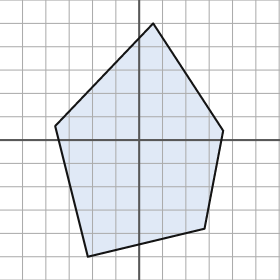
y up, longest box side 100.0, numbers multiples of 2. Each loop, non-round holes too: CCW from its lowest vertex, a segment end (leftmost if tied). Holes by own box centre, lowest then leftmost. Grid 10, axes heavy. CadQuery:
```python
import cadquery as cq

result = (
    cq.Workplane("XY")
    .moveTo(-22.0, -50.0)
    .lineTo(28.0, -38.0)
    .lineTo(36.0, 4.0)
    .lineTo(6.0, 50.0)
    .lineTo(-36.0, 6.0)
    .close()
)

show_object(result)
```